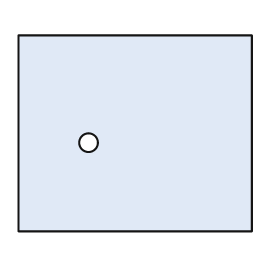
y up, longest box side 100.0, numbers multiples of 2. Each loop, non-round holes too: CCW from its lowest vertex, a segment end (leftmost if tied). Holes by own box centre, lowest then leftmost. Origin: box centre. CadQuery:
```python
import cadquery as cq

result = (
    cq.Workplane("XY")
    .moveTo(-50.0, -42.0)
    .lineTo(50.0, -42.0)
    .lineTo(50.0, 42.0)
    .lineTo(-50.0, 42.0)
    .close()
    .moveTo(-20.0, -4.0)
    .circle(4.0)
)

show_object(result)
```